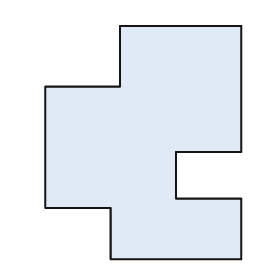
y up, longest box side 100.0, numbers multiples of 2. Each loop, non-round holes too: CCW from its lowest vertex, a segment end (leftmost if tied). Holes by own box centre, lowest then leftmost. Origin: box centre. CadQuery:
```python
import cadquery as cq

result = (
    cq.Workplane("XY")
    .moveTo(-14.0, -50.0)
    .lineTo(42.0, -50.0)
    .lineTo(42.0, -24.0)
    .lineTo(14.0, -24.0)
    .lineTo(14.0, -4.0)
    .lineTo(42.0, -4.0)
    .lineTo(42.0, 50.0)
    .lineTo(-10.0, 50.0)
    .lineTo(-10.0, 24.0)
    .lineTo(-42.0, 24.0)
    .lineTo(-42.0, -28.0)
    .lineTo(-14.0, -28.0)
    .close()
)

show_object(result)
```